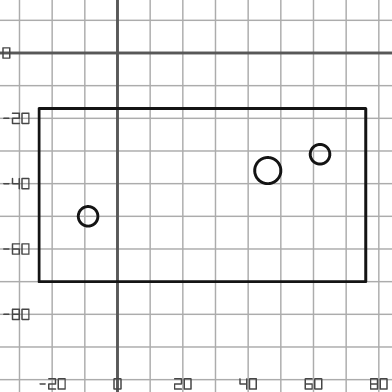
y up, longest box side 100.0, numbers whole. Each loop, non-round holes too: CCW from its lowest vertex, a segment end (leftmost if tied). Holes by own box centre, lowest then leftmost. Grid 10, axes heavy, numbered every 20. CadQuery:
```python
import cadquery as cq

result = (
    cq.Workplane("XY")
    .moveTo(-24.0, -70.0)
    .lineTo(76.0, -70.0)
    .lineTo(76.0, -17.0)
    .lineTo(-24.0, -17.0)
    .close()
    .moveTo(-9.0, -50.0)
    .circle(3.0)
    .moveTo(46.0, -36.0)
    .circle(4.0)
    .moveTo(62.0, -31.0)
    .circle(3.0)
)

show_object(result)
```